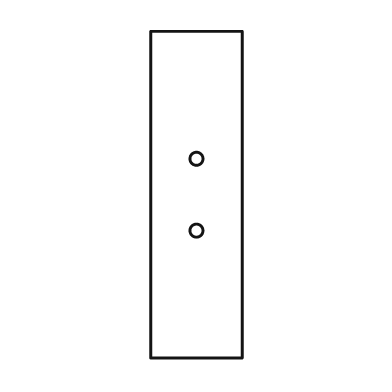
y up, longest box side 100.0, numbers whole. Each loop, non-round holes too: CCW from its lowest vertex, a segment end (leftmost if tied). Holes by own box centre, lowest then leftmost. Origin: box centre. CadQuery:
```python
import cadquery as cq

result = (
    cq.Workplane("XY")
    .moveTo(-14.0, -50.0)
    .lineTo(14.0, -50.0)
    .lineTo(14.0, 50.0)
    .lineTo(-14.0, 50.0)
    .close()
    .moveTo(0.0, -11.0)
    .circle(2.0)
    .moveTo(0.0, 11.0)
    .circle(2.0)
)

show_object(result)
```